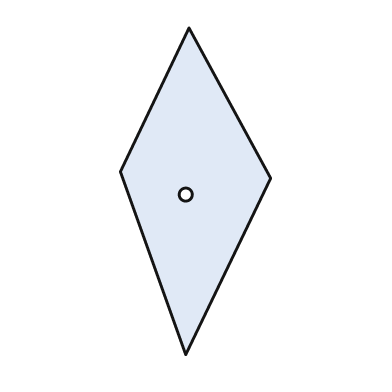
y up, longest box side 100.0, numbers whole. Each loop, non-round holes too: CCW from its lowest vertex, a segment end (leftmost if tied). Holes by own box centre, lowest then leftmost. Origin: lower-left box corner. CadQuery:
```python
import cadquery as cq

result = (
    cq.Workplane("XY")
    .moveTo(20.0, 0.0)
    .lineTo(46.0, 54.0)
    .lineTo(21.0, 100.0)
    .lineTo(0.0, 56.0)
    .close()
    .moveTo(20.0, 49.0)
    .circle(2.0)
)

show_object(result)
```